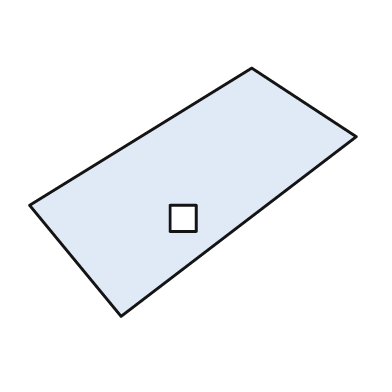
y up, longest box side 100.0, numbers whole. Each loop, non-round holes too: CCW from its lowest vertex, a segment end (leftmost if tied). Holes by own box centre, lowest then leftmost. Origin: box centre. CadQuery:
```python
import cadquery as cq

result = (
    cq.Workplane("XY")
    .moveTo(-22.0, -38.0)
    .lineTo(50.0, 17.0)
    .lineTo(18.0, 38.0)
    .lineTo(-50.0, -4.0)
    .close()
    .moveTo(-7.0, -12.0)
    .lineTo(1.0, -12.0)
    .lineTo(1.0, -4.0)
    .lineTo(-7.0, -4.0)
    .close()
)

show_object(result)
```